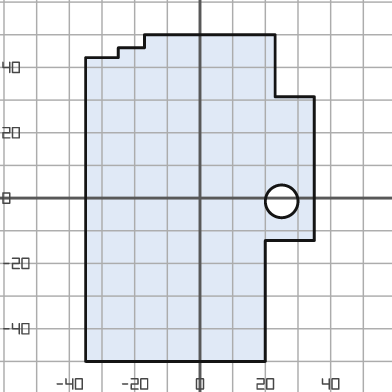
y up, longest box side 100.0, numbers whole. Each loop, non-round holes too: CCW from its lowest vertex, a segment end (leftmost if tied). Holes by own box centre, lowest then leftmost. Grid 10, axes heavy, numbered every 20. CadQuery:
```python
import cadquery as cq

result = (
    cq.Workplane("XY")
    .moveTo(-35.0, -50.0)
    .lineTo(20.0, -50.0)
    .lineTo(20.0, -13.0)
    .lineTo(35.0, -13.0)
    .lineTo(35.0, 31.0)
    .lineTo(23.0, 31.0)
    .lineTo(23.0, 50.0)
    .lineTo(-17.0, 50.0)
    .lineTo(-17.0, 46.0)
    .lineTo(-25.0, 46.0)
    .lineTo(-25.0, 43.0)
    .lineTo(-35.0, 43.0)
    .close()
    .moveTo(25.0, -1.0)
    .circle(5.0)
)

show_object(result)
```